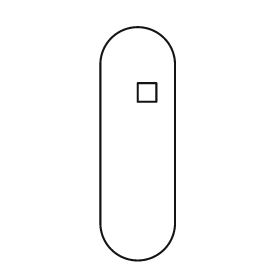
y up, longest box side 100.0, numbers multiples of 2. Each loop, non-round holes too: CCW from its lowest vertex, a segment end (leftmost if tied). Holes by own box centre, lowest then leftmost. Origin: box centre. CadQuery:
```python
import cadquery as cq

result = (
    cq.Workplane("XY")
    .moveTo(-16.0, -34.0)
    .threePointArc((0.0, -50.0), (16.0, -34.0))
    .lineTo(16.0, 34.0)
    .threePointArc((0.0, 50.0), (-16.0, 34.0))
    .close()
    .moveTo(0.0, 18.0)
    .lineTo(8.0, 18.0)
    .lineTo(8.0, 26.0)
    .lineTo(0.0, 26.0)
    .close()
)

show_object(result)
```